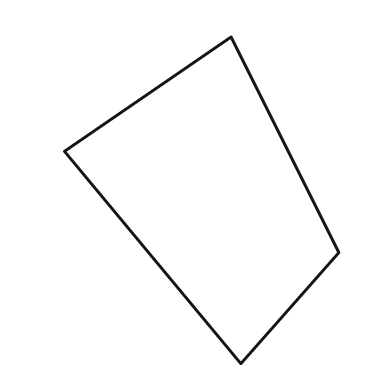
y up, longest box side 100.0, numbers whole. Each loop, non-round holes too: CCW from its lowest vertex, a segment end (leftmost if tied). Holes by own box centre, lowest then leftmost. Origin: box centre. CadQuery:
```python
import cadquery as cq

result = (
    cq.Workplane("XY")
    .moveTo(12.0, -50.0)
    .lineTo(42.0, -16.0)
    .lineTo(9.0, 50.0)
    .lineTo(-42.0, 15.0)
    .close()
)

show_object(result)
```